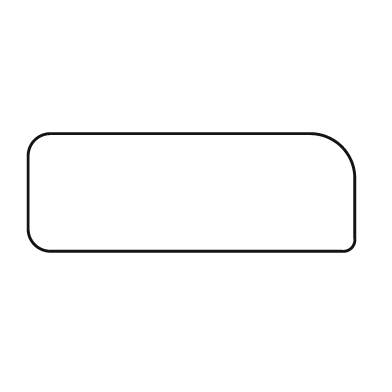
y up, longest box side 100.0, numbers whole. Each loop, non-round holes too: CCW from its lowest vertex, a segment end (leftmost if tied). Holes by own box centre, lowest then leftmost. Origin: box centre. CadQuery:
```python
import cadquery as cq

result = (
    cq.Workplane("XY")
    .moveTo(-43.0, -18.0)
    .lineTo(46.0, -18.0)
    .threePointArc((49.0, -17.0), (50.0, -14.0))
    .lineTo(50.0, 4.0)
    .threePointArc((46.0, 14.0), (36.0, 18.0))
    .lineTo(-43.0, 18.0)
    .threePointArc((-48.0, 16.0), (-50.0, 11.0))
    .lineTo(-50.0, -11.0)
    .threePointArc((-48.0, -16.0), (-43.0, -18.0))
    .close()
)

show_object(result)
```